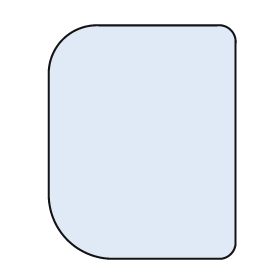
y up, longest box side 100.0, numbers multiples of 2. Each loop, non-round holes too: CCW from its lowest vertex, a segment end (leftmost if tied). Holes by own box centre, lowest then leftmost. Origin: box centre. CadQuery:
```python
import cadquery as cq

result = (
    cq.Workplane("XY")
    .moveTo(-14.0, -50.0)
    .lineTo(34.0, -50.0)
    .threePointArc((38.0, -48.0), (40.0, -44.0))
    .lineTo(40.0, 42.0)
    .threePointArc((38.0, 48.0), (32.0, 50.0))
    .lineTo(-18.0, 50.0)
    .threePointArc((-34.0, 44.0), (-40.0, 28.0))
    .lineTo(-40.0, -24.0)
    .threePointArc((-32.0, -42.0), (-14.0, -50.0))
    .close()
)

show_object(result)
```